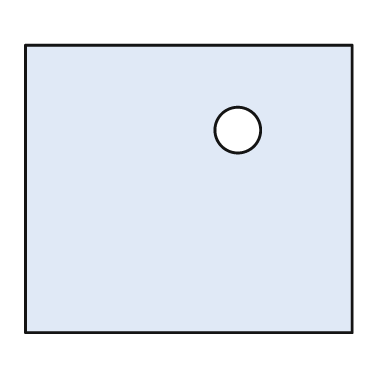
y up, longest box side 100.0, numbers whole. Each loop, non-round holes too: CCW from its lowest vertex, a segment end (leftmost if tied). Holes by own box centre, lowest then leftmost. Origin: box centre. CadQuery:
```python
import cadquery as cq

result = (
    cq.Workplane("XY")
    .moveTo(-50.0, -44.0)
    .lineTo(50.0, -44.0)
    .lineTo(50.0, 44.0)
    .lineTo(-50.0, 44.0)
    .close()
    .moveTo(15.0, 18.0)
    .circle(7.0)
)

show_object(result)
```